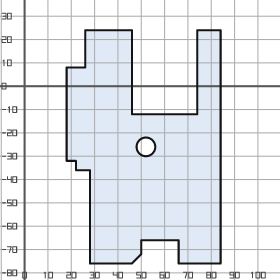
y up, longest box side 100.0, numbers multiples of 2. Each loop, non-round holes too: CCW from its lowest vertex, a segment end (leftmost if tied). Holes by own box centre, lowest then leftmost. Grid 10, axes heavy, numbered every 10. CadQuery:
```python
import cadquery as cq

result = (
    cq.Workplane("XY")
    .moveTo(28.0, -76.0)
    .lineTo(46.0, -76.0)
    .lineTo(50.0, -72.0)
    .lineTo(50.0, -66.0)
    .lineTo(66.0, -66.0)
    .lineTo(66.0, -76.0)
    .lineTo(84.0, -76.0)
    .lineTo(84.0, 24.0)
    .lineTo(74.0, 24.0)
    .lineTo(74.0, -12.0)
    .lineTo(46.0, -12.0)
    .lineTo(46.0, 24.0)
    .lineTo(26.0, 24.0)
    .lineTo(26.0, 8.0)
    .lineTo(18.0, 8.0)
    .lineTo(18.0, -32.0)
    .lineTo(22.0, -32.0)
    .lineTo(22.0, -36.0)
    .lineTo(28.0, -36.0)
    .close()
    .moveTo(52.0, -26.0)
    .circle(4.0)
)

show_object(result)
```